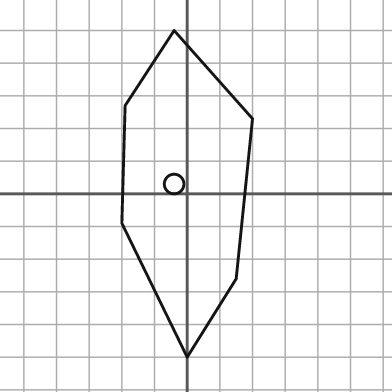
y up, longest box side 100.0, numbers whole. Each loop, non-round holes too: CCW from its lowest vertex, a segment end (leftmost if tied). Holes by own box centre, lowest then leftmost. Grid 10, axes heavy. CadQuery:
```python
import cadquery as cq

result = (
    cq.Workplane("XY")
    .moveTo(0.0, -50.0)
    .lineTo(15.0, -26.0)
    .lineTo(20.0, 23.0)
    .lineTo(-4.0, 50.0)
    .lineTo(-19.0, 27.0)
    .lineTo(-20.0, -9.0)
    .close()
    .moveTo(-4.0, 3.0)
    .circle(3.0)
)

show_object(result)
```